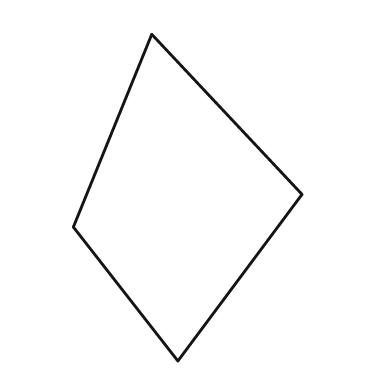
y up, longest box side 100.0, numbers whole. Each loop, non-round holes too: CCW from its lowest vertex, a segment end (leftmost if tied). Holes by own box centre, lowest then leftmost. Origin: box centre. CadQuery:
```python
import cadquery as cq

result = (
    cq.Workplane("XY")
    .moveTo(-3.0, -50.0)
    .lineTo(35.0, 1.0)
    .lineTo(-11.0, 50.0)
    .lineTo(-35.0, -9.0)
    .close()
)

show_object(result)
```